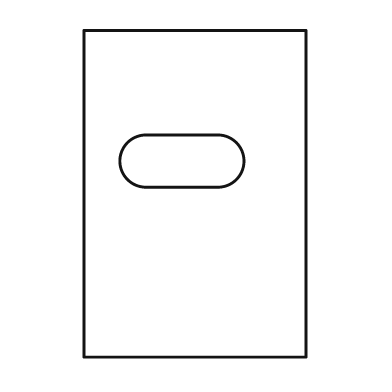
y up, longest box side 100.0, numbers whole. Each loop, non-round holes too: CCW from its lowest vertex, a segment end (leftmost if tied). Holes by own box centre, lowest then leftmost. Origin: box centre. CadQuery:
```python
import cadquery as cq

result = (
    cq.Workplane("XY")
    .moveTo(-34.0, -50.0)
    .lineTo(34.0, -50.0)
    .lineTo(34.0, 50.0)
    .lineTo(-34.0, 50.0)
    .close()
    .moveTo(-15.0, 2.0)
    .lineTo(7.0, 2.0)
    .threePointArc((15.0, 10.0), (7.0, 18.0))
    .lineTo(-15.0, 18.0)
    .threePointArc((-23.0, 10.0), (-15.0, 2.0))
    .close()
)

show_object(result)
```